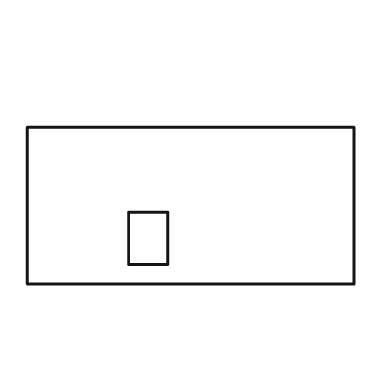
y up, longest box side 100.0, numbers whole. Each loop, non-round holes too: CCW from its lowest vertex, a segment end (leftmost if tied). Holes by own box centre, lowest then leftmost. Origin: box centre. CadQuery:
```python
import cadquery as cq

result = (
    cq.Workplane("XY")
    .moveTo(-50.0, -24.0)
    .lineTo(50.0, -24.0)
    .lineTo(50.0, 24.0)
    .lineTo(-50.0, 24.0)
    .close()
    .moveTo(-19.0, -18.0)
    .lineTo(-7.0, -18.0)
    .lineTo(-7.0, -2.0)
    .lineTo(-19.0, -2.0)
    .close()
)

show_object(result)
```